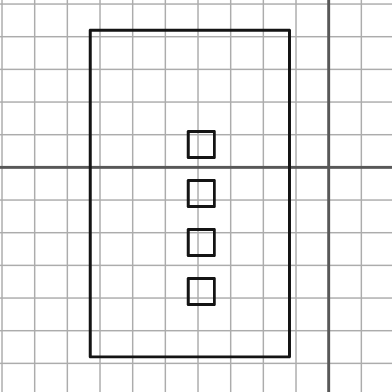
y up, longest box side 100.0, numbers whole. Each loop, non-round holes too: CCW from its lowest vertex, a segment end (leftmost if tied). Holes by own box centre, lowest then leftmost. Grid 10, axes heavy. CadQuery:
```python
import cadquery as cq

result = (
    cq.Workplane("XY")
    .moveTo(-73.0, -58.0)
    .lineTo(-12.0, -58.0)
    .lineTo(-12.0, 42.0)
    .lineTo(-73.0, 42.0)
    .close()
    .moveTo(-43.0, -42.0)
    .lineTo(-35.0, -42.0)
    .lineTo(-35.0, -34.0)
    .lineTo(-43.0, -34.0)
    .close()
    .moveTo(-43.0, -27.0)
    .lineTo(-35.0, -27.0)
    .lineTo(-35.0, -19.0)
    .lineTo(-43.0, -19.0)
    .close()
    .moveTo(-43.0, -12.0)
    .lineTo(-35.0, -12.0)
    .lineTo(-35.0, -4.0)
    .lineTo(-43.0, -4.0)
    .close()
    .moveTo(-43.0, 3.0)
    .lineTo(-35.0, 3.0)
    .lineTo(-35.0, 11.0)
    .lineTo(-43.0, 11.0)
    .close()
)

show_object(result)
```